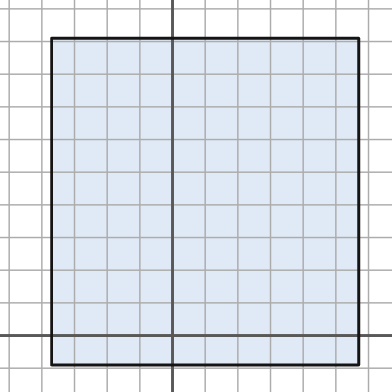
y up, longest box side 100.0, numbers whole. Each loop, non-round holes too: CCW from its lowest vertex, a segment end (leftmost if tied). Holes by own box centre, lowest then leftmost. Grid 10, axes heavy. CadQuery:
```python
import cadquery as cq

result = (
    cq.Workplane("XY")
    .moveTo(-37.0, -9.0)
    .lineTo(57.0, -9.0)
    .lineTo(57.0, 91.0)
    .lineTo(-37.0, 91.0)
    .close()
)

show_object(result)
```